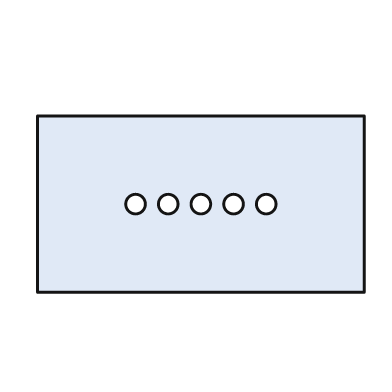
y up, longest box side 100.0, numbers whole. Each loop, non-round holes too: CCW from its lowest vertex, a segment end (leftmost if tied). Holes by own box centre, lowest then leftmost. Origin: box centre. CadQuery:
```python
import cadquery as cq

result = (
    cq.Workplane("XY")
    .moveTo(-50.0, -27.0)
    .lineTo(50.0, -27.0)
    .lineTo(50.0, 27.0)
    .lineTo(-50.0, 27.0)
    .close()
    .moveTo(-20.0, 0.0)
    .circle(3.0)
    .moveTo(-10.0, 0.0)
    .circle(3.0)
    .moveTo(0.0, 0.0)
    .circle(3.0)
    .moveTo(10.0, 0.0)
    .circle(3.0)
    .moveTo(20.0, 0.0)
    .circle(3.0)
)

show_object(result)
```